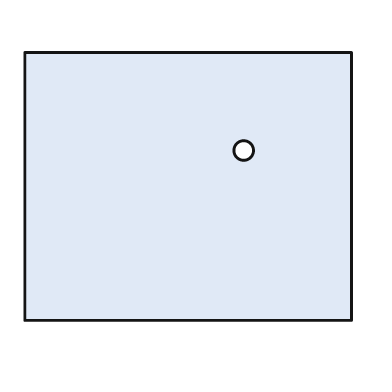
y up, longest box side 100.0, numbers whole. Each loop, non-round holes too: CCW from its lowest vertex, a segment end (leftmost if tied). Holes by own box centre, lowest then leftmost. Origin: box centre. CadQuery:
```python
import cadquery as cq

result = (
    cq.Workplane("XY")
    .moveTo(-50.0, -41.0)
    .lineTo(50.0, -41.0)
    .lineTo(50.0, 41.0)
    .lineTo(-50.0, 41.0)
    .close()
    .moveTo(17.0, 11.0)
    .circle(3.0)
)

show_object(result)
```